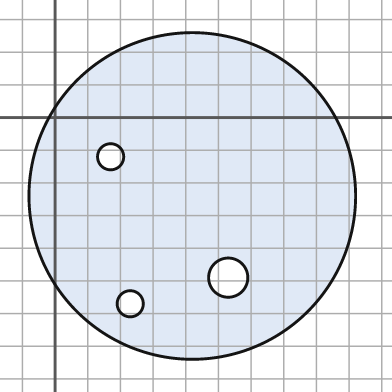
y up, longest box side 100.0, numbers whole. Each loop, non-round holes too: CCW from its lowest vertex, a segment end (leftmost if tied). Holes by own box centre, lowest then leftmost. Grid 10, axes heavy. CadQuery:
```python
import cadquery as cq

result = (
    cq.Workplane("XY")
    .moveTo(42.0, -24.0)
    .circle(50.0)
    .moveTo(23.0, -57.0)
    .circle(4.0)
    .moveTo(53.0, -49.0)
    .circle(6.0)
    .moveTo(17.0, -12.0)
    .circle(4.0)
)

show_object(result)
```